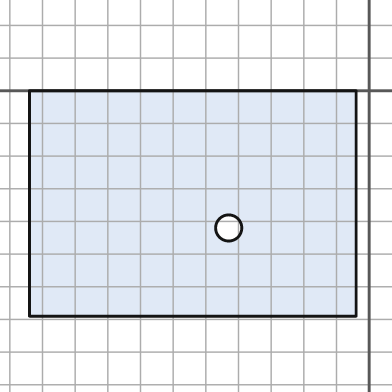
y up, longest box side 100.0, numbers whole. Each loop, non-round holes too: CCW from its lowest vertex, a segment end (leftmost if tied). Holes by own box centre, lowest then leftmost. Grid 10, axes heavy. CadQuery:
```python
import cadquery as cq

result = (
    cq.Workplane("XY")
    .moveTo(-104.0, -69.0)
    .lineTo(-4.0, -69.0)
    .lineTo(-4.0, 0.0)
    .lineTo(-104.0, 0.0)
    .close()
    .moveTo(-43.0, -42.0)
    .circle(4.0)
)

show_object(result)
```